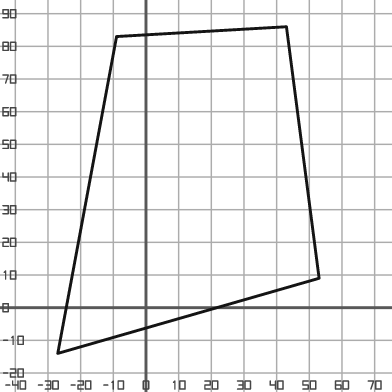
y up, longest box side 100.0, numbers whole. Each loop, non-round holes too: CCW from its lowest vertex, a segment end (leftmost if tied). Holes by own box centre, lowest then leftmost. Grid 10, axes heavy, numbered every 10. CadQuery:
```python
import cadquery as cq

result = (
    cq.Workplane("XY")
    .moveTo(-27.0, -14.0)
    .lineTo(53.0, 9.0)
    .lineTo(43.0, 86.0)
    .lineTo(-9.0, 83.0)
    .close()
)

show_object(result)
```